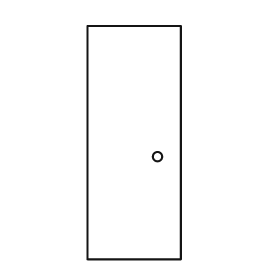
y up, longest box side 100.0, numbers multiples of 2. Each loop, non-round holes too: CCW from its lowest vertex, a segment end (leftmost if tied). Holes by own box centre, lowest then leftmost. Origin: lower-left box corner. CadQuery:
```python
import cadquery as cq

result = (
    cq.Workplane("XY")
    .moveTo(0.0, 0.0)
    .lineTo(40.0, 0.0)
    .lineTo(40.0, 100.0)
    .lineTo(0.0, 100.0)
    .close()
    .moveTo(30.0, 44.0)
    .circle(2.0)
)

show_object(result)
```